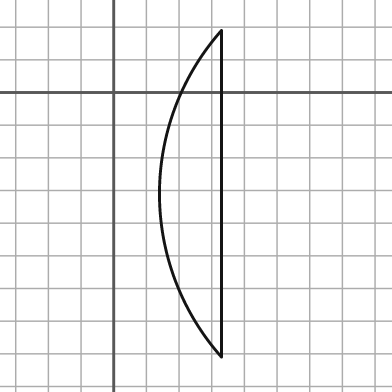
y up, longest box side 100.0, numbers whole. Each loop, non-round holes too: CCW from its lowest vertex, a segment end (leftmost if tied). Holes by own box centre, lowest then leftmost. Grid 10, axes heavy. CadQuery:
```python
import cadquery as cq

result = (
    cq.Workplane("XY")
    .moveTo(33.0, -81.0)
    .lineTo(33.0, 19.0)
    .threePointArc((14.0, -31.0), (33.0, -81.0))
    .close()
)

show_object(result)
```